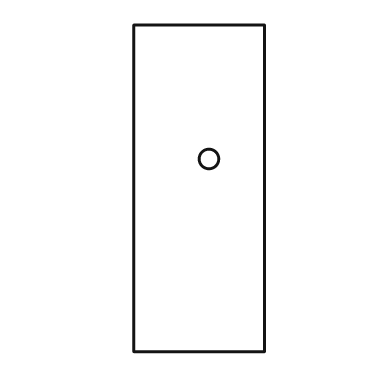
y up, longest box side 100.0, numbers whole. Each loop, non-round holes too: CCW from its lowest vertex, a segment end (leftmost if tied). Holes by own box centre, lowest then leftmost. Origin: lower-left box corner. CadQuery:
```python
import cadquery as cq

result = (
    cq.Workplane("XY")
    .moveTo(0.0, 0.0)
    .lineTo(40.0, 0.0)
    .lineTo(40.0, 100.0)
    .lineTo(0.0, 100.0)
    .close()
    .moveTo(23.0, 59.0)
    .circle(3.0)
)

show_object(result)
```